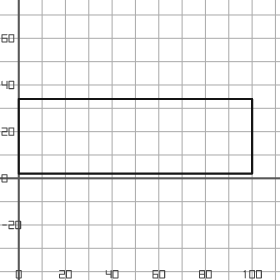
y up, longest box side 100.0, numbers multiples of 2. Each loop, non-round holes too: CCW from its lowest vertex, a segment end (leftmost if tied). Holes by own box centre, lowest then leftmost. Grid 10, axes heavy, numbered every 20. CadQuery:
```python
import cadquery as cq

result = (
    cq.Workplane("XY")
    .moveTo(0.0, 2.0)
    .lineTo(100.0, 2.0)
    .lineTo(100.0, 34.0)
    .lineTo(0.0, 34.0)
    .close()
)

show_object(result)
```